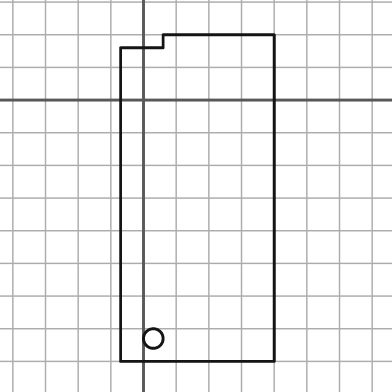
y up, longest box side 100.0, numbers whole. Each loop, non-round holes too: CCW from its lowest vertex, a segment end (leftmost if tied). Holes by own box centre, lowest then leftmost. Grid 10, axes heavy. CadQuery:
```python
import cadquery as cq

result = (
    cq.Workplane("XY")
    .moveTo(-7.0, -80.0)
    .lineTo(40.0, -80.0)
    .lineTo(40.0, 20.0)
    .lineTo(6.0, 20.0)
    .lineTo(6.0, 16.0)
    .lineTo(-7.0, 16.0)
    .close()
    .moveTo(3.0, -73.0)
    .circle(3.0)
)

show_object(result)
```